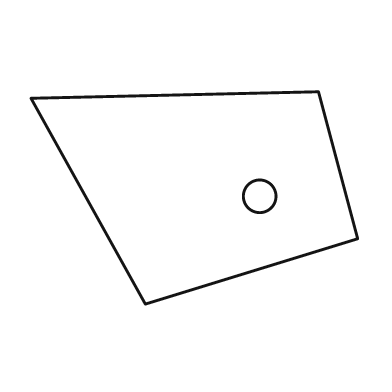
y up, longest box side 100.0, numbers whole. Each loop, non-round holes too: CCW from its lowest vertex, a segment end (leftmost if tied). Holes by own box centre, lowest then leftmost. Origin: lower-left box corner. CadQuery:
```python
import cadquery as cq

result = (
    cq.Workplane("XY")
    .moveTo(35.0, 0.0)
    .lineTo(100.0, 20.0)
    .lineTo(88.0, 65.0)
    .lineTo(0.0, 63.0)
    .close()
    .moveTo(70.0, 33.0)
    .circle(5.0)
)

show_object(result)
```